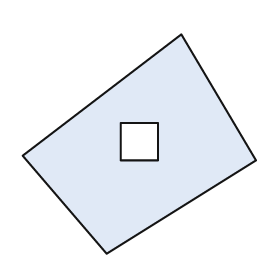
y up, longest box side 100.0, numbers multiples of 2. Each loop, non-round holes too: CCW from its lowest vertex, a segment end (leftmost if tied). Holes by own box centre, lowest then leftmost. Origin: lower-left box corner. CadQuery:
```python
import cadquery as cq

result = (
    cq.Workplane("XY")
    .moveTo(36.0, 0.0)
    .lineTo(100.0, 40.0)
    .lineTo(68.0, 94.0)
    .lineTo(0.0, 42.0)
    .close()
    .moveTo(42.0, 40.0)
    .lineTo(58.0, 40.0)
    .lineTo(58.0, 56.0)
    .lineTo(42.0, 56.0)
    .close()
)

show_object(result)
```